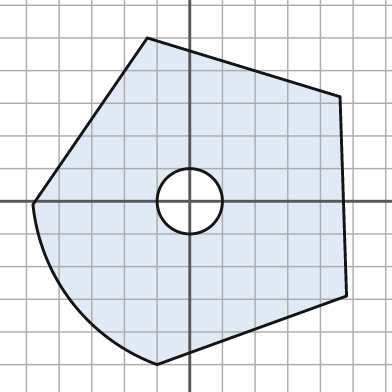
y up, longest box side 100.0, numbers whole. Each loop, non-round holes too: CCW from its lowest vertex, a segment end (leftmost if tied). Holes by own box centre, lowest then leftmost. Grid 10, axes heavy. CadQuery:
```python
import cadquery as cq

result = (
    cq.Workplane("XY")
    .moveTo(-10.0, -50.0)
    .lineTo(48.0, -29.0)
    .lineTo(46.0, 32.0)
    .lineTo(-13.0, 50.0)
    .lineTo(-48.0, -1.0)
    .threePointArc((-36.0, -31.0), (-10.0, -50.0))
    .close()
    .moveTo(0.0, 0.0)
    .circle(10.0)
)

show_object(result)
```